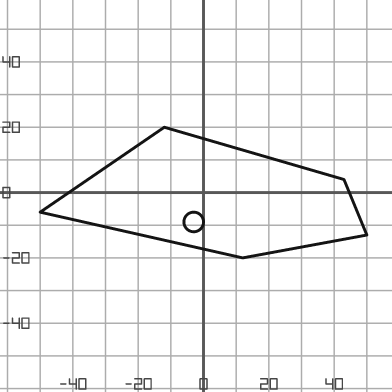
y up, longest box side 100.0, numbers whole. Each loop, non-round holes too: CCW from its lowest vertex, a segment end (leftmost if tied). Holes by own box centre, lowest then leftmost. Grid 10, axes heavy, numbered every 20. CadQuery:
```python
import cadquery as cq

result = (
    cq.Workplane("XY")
    .moveTo(12.0, -20.0)
    .lineTo(50.0, -13.0)
    .lineTo(43.0, 4.0)
    .lineTo(-12.0, 20.0)
    .lineTo(-50.0, -6.0)
    .close()
    .moveTo(-3.0, -9.0)
    .circle(3.0)
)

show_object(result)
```